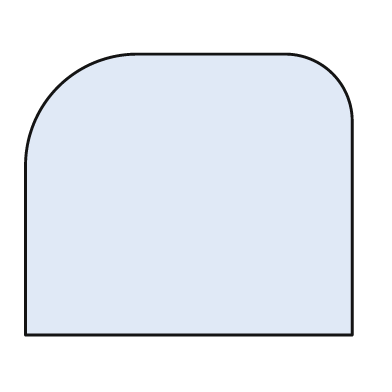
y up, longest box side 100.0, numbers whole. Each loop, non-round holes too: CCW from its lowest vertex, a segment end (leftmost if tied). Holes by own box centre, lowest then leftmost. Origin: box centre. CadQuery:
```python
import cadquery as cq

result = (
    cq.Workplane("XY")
    .moveTo(-50.0, -43.0)
    .lineTo(50.0, -43.0)
    .lineTo(50.0, 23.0)
    .threePointArc((44.0, 37.0), (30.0, 43.0))
    .lineTo(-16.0, 43.0)
    .threePointArc((-40.0, 33.0), (-50.0, 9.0))
    .close()
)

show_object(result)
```